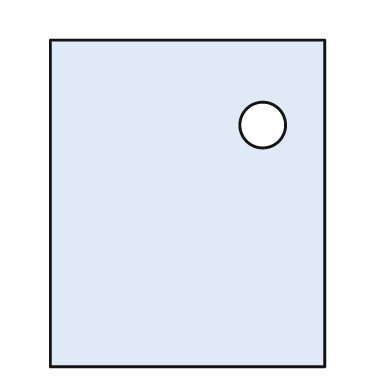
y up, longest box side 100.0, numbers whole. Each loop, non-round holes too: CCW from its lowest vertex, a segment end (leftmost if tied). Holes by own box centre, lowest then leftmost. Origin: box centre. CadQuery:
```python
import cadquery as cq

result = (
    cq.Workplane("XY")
    .moveTo(-42.0, -50.0)
    .lineTo(42.0, -50.0)
    .lineTo(42.0, 50.0)
    .lineTo(-42.0, 50.0)
    .close()
    .moveTo(23.0, 24.0)
    .circle(7.0)
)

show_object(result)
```